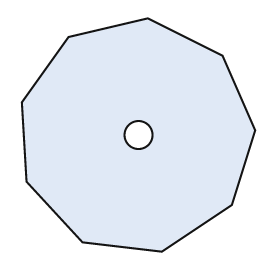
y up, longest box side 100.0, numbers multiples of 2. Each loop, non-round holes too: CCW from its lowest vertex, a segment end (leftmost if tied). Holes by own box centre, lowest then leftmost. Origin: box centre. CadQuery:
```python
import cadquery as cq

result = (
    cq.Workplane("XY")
    .moveTo(10.0, -50.0)
    .lineTo(40.0, -30.0)
    .lineTo(50.0, 2.0)
    .lineTo(36.0, 34.0)
    .lineTo(4.0, 50.0)
    .lineTo(-30.0, 42.0)
    .lineTo(-50.0, 14.0)
    .lineTo(-48.0, -20.0)
    .lineTo(-24.0, -46.0)
    .close()
    .moveTo(0.0, 0.0)
    .circle(6.0)
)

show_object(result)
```